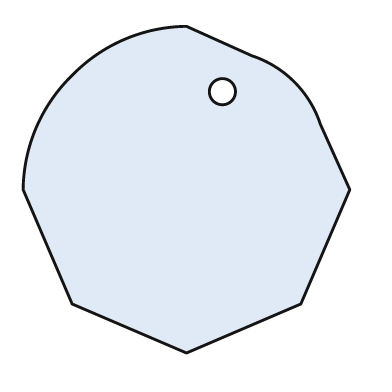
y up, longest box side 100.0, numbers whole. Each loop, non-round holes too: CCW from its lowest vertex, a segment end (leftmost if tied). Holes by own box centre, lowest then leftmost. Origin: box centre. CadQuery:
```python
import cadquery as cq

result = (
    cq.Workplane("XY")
    .moveTo(0.0, -50.0)
    .lineTo(35.0, -35.0)
    .lineTo(50.0, 0.0)
    .lineTo(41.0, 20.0)
    .threePointArc((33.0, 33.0), (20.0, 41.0))
    .lineTo(0.0, 50.0)
    .threePointArc((-19.0, 46.0), (-35.0, 35.0))
    .threePointArc((-46.0, 19.0), (-50.0, 0.0))
    .lineTo(-35.0, -35.0)
    .close()
    .moveTo(11.0, 30.0)
    .circle(4.0)
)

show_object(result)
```